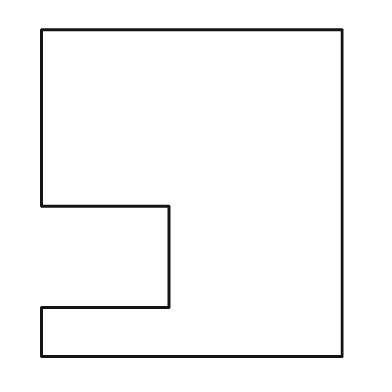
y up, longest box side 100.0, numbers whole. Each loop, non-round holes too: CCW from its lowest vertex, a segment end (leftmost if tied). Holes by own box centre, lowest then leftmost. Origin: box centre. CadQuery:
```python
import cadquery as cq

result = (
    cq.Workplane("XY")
    .moveTo(-46.0, -50.0)
    .lineTo(46.0, -50.0)
    .lineTo(46.0, 50.0)
    .lineTo(-46.0, 50.0)
    .lineTo(-46.0, -4.0)
    .lineTo(-7.0, -4.0)
    .lineTo(-7.0, -35.0)
    .lineTo(-46.0, -35.0)
    .close()
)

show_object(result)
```